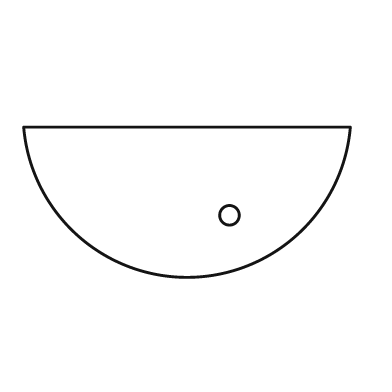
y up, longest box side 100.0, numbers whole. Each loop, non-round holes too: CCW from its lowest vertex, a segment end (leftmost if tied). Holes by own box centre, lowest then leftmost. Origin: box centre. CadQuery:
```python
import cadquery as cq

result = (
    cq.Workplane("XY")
    .moveTo(-50.0, 23.0)
    .threePointArc((0.0, -23.0), (50.0, 23.0))
    .close()
    .moveTo(13.0, -4.0)
    .circle(3.0)
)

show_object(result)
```